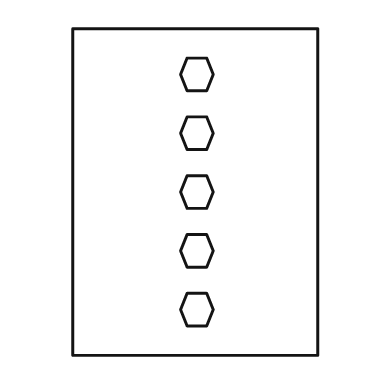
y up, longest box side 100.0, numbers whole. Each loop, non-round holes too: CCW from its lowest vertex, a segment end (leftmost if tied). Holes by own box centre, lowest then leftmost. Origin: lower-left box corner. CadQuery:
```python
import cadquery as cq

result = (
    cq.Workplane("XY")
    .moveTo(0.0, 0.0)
    .lineTo(75.0, 0.0)
    .lineTo(75.0, 100.0)
    .lineTo(0.0, 100.0)
    .close()
    .moveTo(35.0, 9.0)
    .lineTo(41.0, 9.0)
    .lineTo(43.0, 14.0)
    .lineTo(41.0, 19.0)
    .lineTo(35.0, 19.0)
    .lineTo(33.0, 14.0)
    .close()
    .moveTo(35.0, 27.0)
    .lineTo(41.0, 27.0)
    .lineTo(43.0, 32.0)
    .lineTo(41.0, 37.0)
    .lineTo(35.0, 37.0)
    .lineTo(33.0, 32.0)
    .close()
    .moveTo(35.0, 45.0)
    .lineTo(41.0, 45.0)
    .lineTo(43.0, 50.0)
    .lineTo(41.0, 55.0)
    .lineTo(35.0, 55.0)
    .lineTo(33.0, 50.0)
    .close()
    .moveTo(35.0, 63.0)
    .lineTo(41.0, 63.0)
    .lineTo(43.0, 68.0)
    .lineTo(41.0, 73.0)
    .lineTo(35.0, 73.0)
    .lineTo(33.0, 68.0)
    .close()
    .moveTo(35.0, 81.0)
    .lineTo(41.0, 81.0)
    .lineTo(43.0, 86.0)
    .lineTo(41.0, 91.0)
    .lineTo(35.0, 91.0)
    .lineTo(33.0, 86.0)
    .close()
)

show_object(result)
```